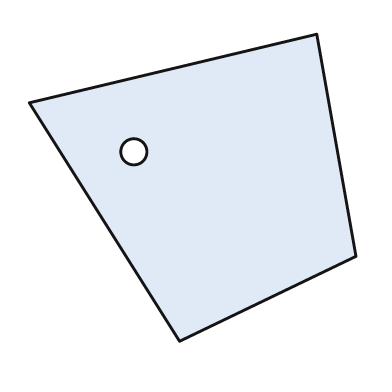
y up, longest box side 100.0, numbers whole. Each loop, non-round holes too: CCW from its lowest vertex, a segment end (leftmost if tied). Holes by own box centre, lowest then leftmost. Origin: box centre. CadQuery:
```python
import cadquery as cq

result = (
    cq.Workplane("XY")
    .moveTo(-4.0, -47.0)
    .lineTo(50.0, -21.0)
    .lineTo(38.0, 47.0)
    .lineTo(-50.0, 26.0)
    .close()
    .moveTo(-18.0, 11.0)
    .circle(4.0)
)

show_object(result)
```